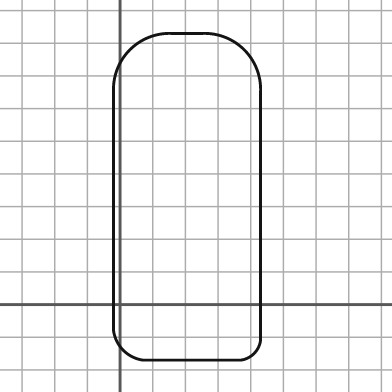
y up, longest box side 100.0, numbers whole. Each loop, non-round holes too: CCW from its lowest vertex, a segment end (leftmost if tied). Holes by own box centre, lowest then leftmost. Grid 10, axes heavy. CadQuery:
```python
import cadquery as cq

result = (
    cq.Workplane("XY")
    .moveTo(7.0, -17.0)
    .lineTo(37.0, -17.0)
    .threePointArc((41.0, -15.0), (43.0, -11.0))
    .lineTo(43.0, 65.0)
    .threePointArc((38.0, 78.0), (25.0, 83.0))
    .lineTo(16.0, 83.0)
    .threePointArc((3.0, 78.0), (-2.0, 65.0))
    .lineTo(-2.0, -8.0)
    .threePointArc((1.0, -14.0), (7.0, -17.0))
    .close()
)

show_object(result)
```